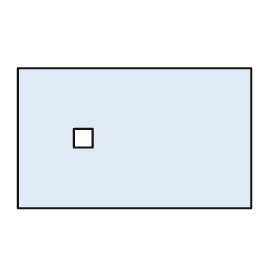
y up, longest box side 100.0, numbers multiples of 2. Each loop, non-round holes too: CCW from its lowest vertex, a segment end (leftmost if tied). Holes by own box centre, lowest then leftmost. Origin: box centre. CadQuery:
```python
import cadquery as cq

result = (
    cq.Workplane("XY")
    .moveTo(-50.0, -30.0)
    .lineTo(50.0, -30.0)
    .lineTo(50.0, 30.0)
    .lineTo(-50.0, 30.0)
    .close()
    .moveTo(-26.0, -4.0)
    .lineTo(-18.0, -4.0)
    .lineTo(-18.0, 4.0)
    .lineTo(-26.0, 4.0)
    .close()
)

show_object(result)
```